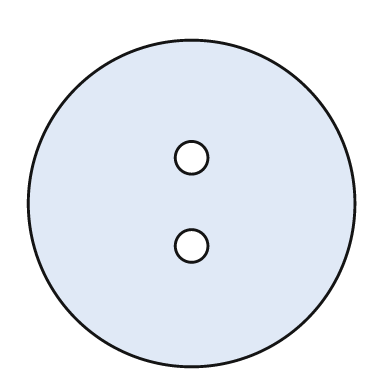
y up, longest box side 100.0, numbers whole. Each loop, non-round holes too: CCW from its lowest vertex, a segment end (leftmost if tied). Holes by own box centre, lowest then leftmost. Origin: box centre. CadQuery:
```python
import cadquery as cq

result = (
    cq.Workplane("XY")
    .moveTo(0.0, 0.0)
    .circle(50.0)
    .moveTo(0.0, -13.0)
    .circle(5.0)
    .moveTo(0.0, 14.0)
    .circle(5.0)
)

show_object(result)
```